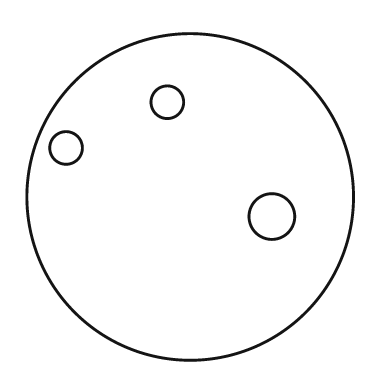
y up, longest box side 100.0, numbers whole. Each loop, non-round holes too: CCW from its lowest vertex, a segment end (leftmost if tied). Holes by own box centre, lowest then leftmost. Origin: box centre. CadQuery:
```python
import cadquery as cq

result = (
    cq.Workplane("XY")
    .moveTo(0.0, 0.0)
    .circle(50.0)
    .moveTo(25.0, -6.0)
    .circle(7.0)
    .moveTo(-38.0, 15.0)
    .circle(5.0)
    .moveTo(-7.0, 29.0)
    .circle(5.0)
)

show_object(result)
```